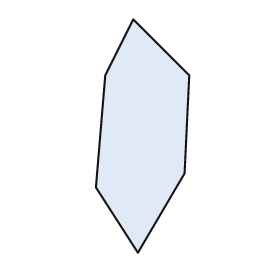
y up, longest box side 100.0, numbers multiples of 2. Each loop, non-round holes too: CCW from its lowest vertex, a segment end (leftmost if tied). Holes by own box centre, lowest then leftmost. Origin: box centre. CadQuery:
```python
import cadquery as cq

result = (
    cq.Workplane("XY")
    .moveTo(-2.0, -50.0)
    .lineTo(18.0, -16.0)
    .lineTo(20.0, 26.0)
    .lineTo(-4.0, 50.0)
    .lineTo(-16.0, 26.0)
    .lineTo(-20.0, -22.0)
    .close()
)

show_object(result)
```